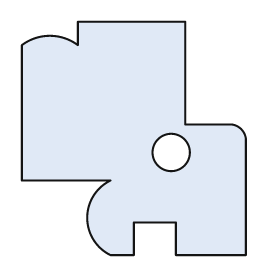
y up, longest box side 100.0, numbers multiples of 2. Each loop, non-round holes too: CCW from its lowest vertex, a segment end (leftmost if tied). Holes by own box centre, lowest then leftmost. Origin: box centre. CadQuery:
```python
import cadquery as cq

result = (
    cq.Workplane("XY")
    .moveTo(-10.0, -50.0)
    .lineTo(0.0, -50.0)
    .lineTo(0.0, -36.0)
    .lineTo(18.0, -36.0)
    .lineTo(18.0, -50.0)
    .lineTo(48.0, -50.0)
    .lineTo(48.0, 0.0)
    .threePointArc((46.0, 4.0), (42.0, 6.0))
    .lineTo(22.0, 6.0)
    .lineTo(22.0, 50.0)
    .lineTo(-24.0, 50.0)
    .lineTo(-24.0, 40.0)
    .threePointArc((-36.0, 44.0), (-48.0, 40.0))
    .lineTo(-48.0, -18.0)
    .lineTo(-10.0, -18.0)
    .threePointArc((-20.0, -34.0), (-10.0, -50.0))
    .close()
    .moveTo(16.0, -6.0)
    .circle(8.0)
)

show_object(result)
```